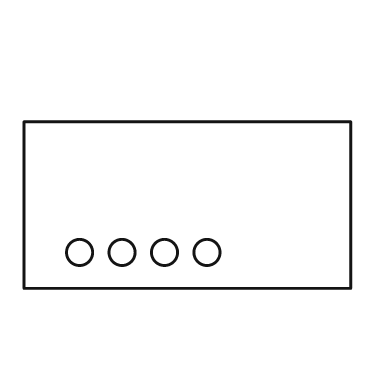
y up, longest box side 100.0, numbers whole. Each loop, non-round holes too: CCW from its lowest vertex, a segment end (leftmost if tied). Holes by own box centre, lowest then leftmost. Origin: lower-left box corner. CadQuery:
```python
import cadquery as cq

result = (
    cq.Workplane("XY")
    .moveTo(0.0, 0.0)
    .lineTo(100.0, 0.0)
    .lineTo(100.0, 51.0)
    .lineTo(0.0, 51.0)
    .close()
    .moveTo(17.0, 11.0)
    .circle(4.0)
    .moveTo(30.0, 11.0)
    .circle(4.0)
    .moveTo(43.0, 11.0)
    .circle(4.0)
    .moveTo(56.0, 11.0)
    .circle(4.0)
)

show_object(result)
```